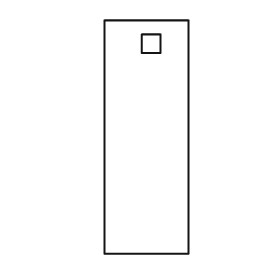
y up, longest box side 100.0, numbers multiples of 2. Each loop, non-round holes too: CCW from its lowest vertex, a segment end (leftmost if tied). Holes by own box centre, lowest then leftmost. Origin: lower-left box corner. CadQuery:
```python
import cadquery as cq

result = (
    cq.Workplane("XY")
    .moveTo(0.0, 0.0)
    .lineTo(36.0, 0.0)
    .lineTo(36.0, 100.0)
    .lineTo(0.0, 100.0)
    .close()
    .moveTo(16.0, 86.0)
    .lineTo(24.0, 86.0)
    .lineTo(24.0, 94.0)
    .lineTo(16.0, 94.0)
    .close()
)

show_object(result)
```